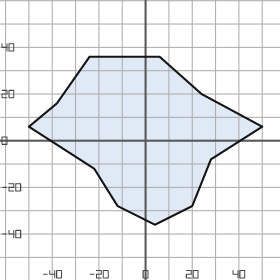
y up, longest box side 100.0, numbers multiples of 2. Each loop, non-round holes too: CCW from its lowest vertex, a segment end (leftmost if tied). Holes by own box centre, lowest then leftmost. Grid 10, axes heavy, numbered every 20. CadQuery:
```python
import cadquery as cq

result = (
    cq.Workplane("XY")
    .moveTo(4.0, -36.0)
    .lineTo(20.0, -28.0)
    .lineTo(28.0, -8.0)
    .lineTo(50.0, 6.0)
    .lineTo(24.0, 20.0)
    .lineTo(6.0, 36.0)
    .lineTo(-24.0, 36.0)
    .lineTo(-38.0, 16.0)
    .lineTo(-50.0, 6.0)
    .lineTo(-22.0, -12.0)
    .lineTo(-12.0, -28.0)
    .close()
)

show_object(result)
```